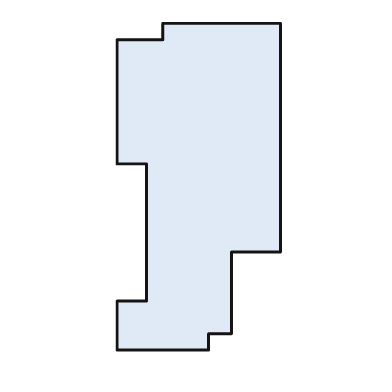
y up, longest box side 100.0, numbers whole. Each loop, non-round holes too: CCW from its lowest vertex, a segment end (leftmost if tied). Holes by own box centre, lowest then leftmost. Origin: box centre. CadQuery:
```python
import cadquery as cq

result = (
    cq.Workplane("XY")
    .moveTo(-25.0, -50.0)
    .lineTo(3.0, -50.0)
    .lineTo(3.0, -45.0)
    .lineTo(10.0, -45.0)
    .lineTo(10.0, -20.0)
    .lineTo(25.0, -20.0)
    .lineTo(25.0, 50.0)
    .lineTo(-11.0, 50.0)
    .lineTo(-11.0, 45.0)
    .lineTo(-25.0, 45.0)
    .lineTo(-25.0, 7.0)
    .lineTo(-16.0, 7.0)
    .lineTo(-16.0, -35.0)
    .lineTo(-25.0, -35.0)
    .close()
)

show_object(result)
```